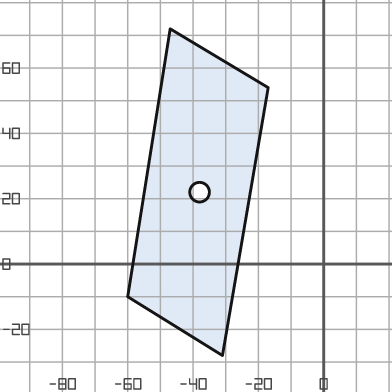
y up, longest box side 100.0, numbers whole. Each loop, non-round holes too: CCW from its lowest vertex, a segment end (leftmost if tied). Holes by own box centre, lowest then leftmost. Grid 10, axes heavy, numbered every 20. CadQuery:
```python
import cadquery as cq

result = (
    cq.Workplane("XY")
    .moveTo(-31.0, -28.0)
    .lineTo(-17.0, 54.0)
    .lineTo(-47.0, 72.0)
    .lineTo(-60.0, -10.0)
    .close()
    .moveTo(-38.0, 22.0)
    .circle(3.0)
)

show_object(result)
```